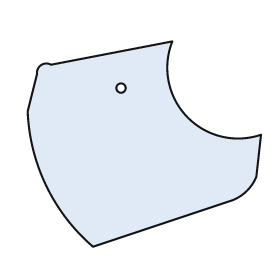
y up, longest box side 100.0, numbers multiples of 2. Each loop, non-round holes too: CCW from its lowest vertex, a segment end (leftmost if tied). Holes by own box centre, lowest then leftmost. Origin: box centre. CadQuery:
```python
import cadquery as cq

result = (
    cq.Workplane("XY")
    .moveTo(-22.0, -44.0)
    .lineTo(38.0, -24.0)
    .threePointArc((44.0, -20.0), (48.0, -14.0))
    .lineTo(50.0, 4.0)
    .threePointArc((18.0, 12.0), (12.0, 44.0))
    .lineTo(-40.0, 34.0)
    .threePointArc((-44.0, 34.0), (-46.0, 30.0))
    .lineTo(-50.0, 14.0)
    .threePointArc((-42.0, -18.0), (-22.0, -44.0))
    .close()
    .moveTo(-10.0, 24.0)
    .circle(2.0)
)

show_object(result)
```